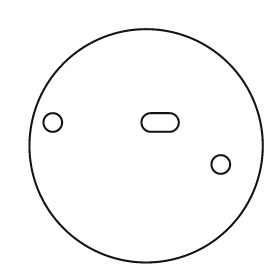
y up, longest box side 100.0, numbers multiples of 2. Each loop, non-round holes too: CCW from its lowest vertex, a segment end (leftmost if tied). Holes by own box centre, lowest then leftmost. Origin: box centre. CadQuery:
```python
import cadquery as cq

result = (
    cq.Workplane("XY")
    .moveTo(0.0, 0.0)
    .circle(50.0)
    .moveTo(32.0, -8.0)
    .circle(4.0)
    .moveTo(-40.0, 10.0)
    .circle(4.0)
    .moveTo(2.0, 6.0)
    .lineTo(10.0, 6.0)
    .threePointArc((14.0, 10.0), (10.0, 14.0))
    .lineTo(2.0, 14.0)
    .threePointArc((-2.0, 10.0), (2.0, 6.0))
    .close()
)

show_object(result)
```